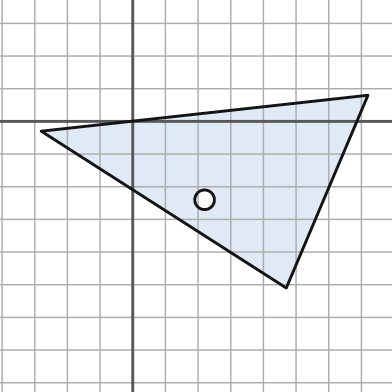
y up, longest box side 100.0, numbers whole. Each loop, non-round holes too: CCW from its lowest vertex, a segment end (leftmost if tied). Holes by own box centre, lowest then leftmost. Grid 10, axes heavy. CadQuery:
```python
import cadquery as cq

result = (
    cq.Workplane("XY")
    .moveTo(47.0, -51.0)
    .lineTo(72.0, 8.0)
    .lineTo(-28.0, -3.0)
    .close()
    .moveTo(22.0, -24.0)
    .circle(3.0)
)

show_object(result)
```